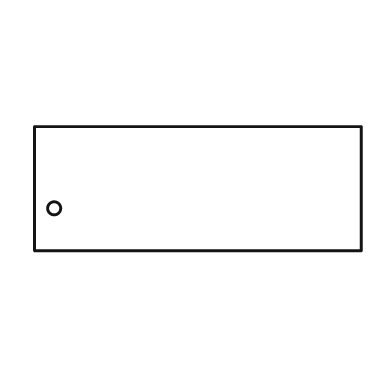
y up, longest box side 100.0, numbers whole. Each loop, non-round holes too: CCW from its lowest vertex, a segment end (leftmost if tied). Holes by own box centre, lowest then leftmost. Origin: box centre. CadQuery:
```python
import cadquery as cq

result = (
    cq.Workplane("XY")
    .moveTo(-50.0, -19.0)
    .lineTo(50.0, -19.0)
    .lineTo(50.0, 19.0)
    .lineTo(-50.0, 19.0)
    .close()
    .moveTo(-44.0, -6.0)
    .circle(2.0)
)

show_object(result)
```